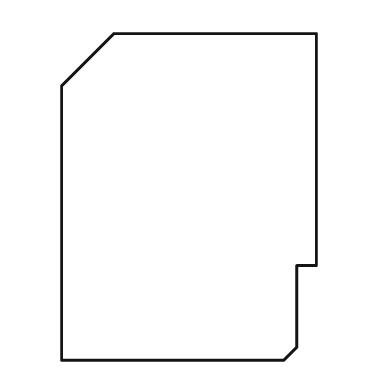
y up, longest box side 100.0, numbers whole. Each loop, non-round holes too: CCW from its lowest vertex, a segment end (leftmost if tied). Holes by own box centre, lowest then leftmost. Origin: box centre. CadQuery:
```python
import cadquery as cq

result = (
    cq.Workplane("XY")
    .moveTo(-39.0, -50.0)
    .lineTo(29.0, -50.0)
    .lineTo(33.0, -46.0)
    .lineTo(33.0, -21.0)
    .lineTo(39.0, -21.0)
    .lineTo(39.0, 50.0)
    .lineTo(-23.0, 50.0)
    .lineTo(-39.0, 34.0)
    .close()
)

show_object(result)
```